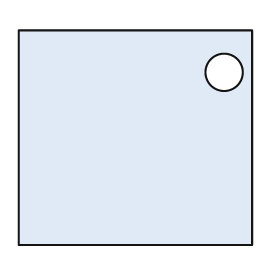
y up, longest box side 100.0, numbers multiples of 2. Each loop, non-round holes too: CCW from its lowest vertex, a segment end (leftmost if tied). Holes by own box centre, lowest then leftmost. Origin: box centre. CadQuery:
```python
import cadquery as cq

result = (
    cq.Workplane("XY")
    .moveTo(-50.0, -46.0)
    .lineTo(50.0, -46.0)
    .lineTo(50.0, 46.0)
    .lineTo(-50.0, 46.0)
    .close()
    .moveTo(38.0, 28.0)
    .circle(8.0)
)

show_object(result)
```